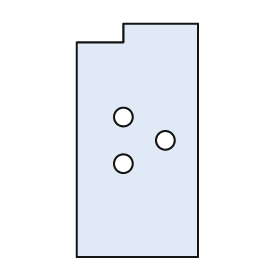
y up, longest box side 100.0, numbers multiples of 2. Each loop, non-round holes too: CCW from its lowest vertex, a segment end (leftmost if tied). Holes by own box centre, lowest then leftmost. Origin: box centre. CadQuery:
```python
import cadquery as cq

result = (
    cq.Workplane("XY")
    .moveTo(-26.0, -50.0)
    .lineTo(26.0, -50.0)
    .lineTo(26.0, 50.0)
    .lineTo(-6.0, 50.0)
    .lineTo(-6.0, 42.0)
    .lineTo(-26.0, 42.0)
    .close()
    .moveTo(-6.0, -10.0)
    .circle(4.0)
    .moveTo(12.0, 0.0)
    .circle(4.0)
    .moveTo(-6.0, 10.0)
    .circle(4.0)
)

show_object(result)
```